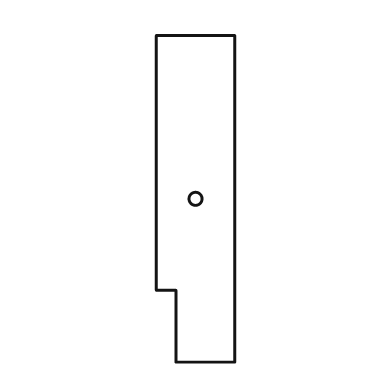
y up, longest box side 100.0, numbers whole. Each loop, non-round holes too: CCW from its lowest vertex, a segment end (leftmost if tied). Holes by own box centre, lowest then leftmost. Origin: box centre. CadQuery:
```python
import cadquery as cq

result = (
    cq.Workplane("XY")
    .moveTo(-6.0, -50.0)
    .lineTo(12.0, -50.0)
    .lineTo(12.0, 50.0)
    .lineTo(-12.0, 50.0)
    .lineTo(-12.0, -28.0)
    .lineTo(-6.0, -28.0)
    .close()
    .moveTo(0.0, 0.0)
    .circle(2.0)
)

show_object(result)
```